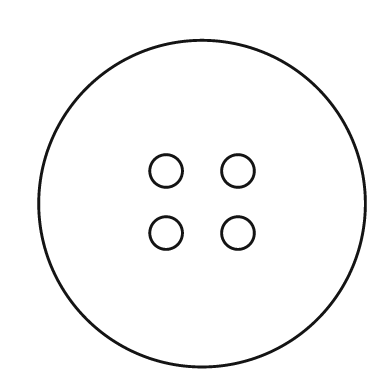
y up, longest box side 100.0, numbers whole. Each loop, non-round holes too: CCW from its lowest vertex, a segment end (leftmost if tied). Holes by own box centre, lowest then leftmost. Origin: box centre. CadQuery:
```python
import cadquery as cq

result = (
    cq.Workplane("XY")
    .moveTo(0.0, 0.0)
    .circle(50.0)
    .moveTo(-11.0, -9.0)
    .circle(5.0)
    .moveTo(11.0, -9.0)
    .circle(5.0)
    .moveTo(-11.0, 10.0)
    .circle(5.0)
    .moveTo(11.0, 10.0)
    .circle(5.0)
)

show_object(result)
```